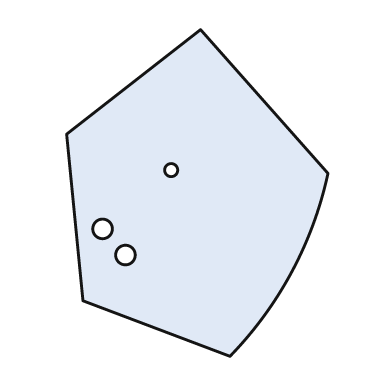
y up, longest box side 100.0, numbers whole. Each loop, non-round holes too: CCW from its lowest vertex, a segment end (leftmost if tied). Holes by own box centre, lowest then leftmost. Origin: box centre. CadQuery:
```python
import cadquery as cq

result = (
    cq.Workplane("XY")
    .moveTo(10.0, -50.0)
    .threePointArc((29.0, -24.0), (40.0, 6.0))
    .lineTo(1.0, 50.0)
    .lineTo(-40.0, 18.0)
    .lineTo(-35.0, -33.0)
    .close()
    .moveTo(-22.0, -19.0)
    .circle(3.0)
    .moveTo(-29.0, -11.0)
    .circle(3.0)
    .moveTo(-8.0, 7.0)
    .circle(2.0)
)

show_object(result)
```